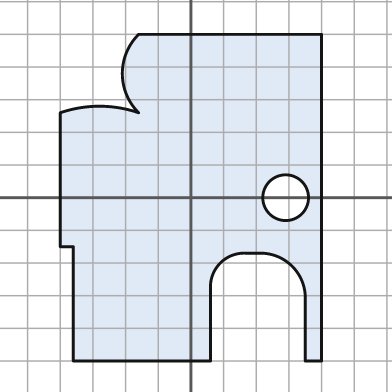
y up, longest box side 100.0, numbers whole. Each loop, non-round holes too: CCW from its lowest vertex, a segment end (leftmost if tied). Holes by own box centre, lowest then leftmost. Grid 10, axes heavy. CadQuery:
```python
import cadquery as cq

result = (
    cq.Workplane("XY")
    .moveTo(-36.0, -50.0)
    .lineTo(6.0, -50.0)
    .lineTo(6.0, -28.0)
    .threePointArc((9.0, -20.0), (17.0, -17.0))
    .lineTo(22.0, -17.0)
    .threePointArc((31.0, -21.0), (35.0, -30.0))
    .lineTo(35.0, -50.0)
    .lineTo(40.0, -50.0)
    .lineTo(40.0, 50.0)
    .lineTo(-16.0, 50.0)
    .threePointArc((-21.0, 38.0), (-16.0, 26.0))
    .threePointArc((-28.0, 28.0), (-40.0, 26.0))
    .lineTo(-40.0, -15.0)
    .lineTo(-36.0, -15.0)
    .close()
    .moveTo(29.0, 0.0)
    .circle(7.0)
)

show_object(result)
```